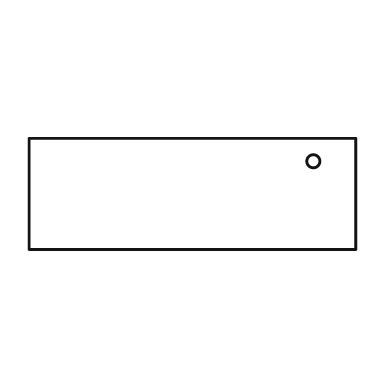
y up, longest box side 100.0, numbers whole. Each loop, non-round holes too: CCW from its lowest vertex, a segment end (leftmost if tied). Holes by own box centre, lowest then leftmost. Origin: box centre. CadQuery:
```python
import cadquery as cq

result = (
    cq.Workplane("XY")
    .moveTo(-50.0, -17.0)
    .lineTo(50.0, -17.0)
    .lineTo(50.0, 17.0)
    .lineTo(-50.0, 17.0)
    .close()
    .moveTo(37.0, 10.0)
    .circle(2.0)
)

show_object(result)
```